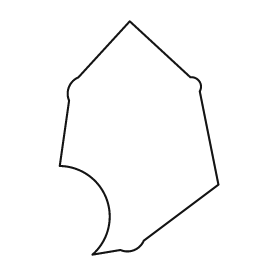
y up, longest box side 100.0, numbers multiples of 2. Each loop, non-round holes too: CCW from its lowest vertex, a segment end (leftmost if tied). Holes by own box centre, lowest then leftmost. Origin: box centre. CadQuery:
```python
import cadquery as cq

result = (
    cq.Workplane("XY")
    .moveTo(-20.0, -50.0)
    .lineTo(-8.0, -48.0)
    .threePointArc((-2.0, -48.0), (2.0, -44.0))
    .lineTo(34.0, -20.0)
    .lineTo(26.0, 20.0)
    .threePointArc((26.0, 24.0), (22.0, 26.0))
    .lineTo(-4.0, 50.0)
    .lineTo(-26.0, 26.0)
    .threePointArc((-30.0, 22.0), (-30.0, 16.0))
    .lineTo(-34.0, -12.0)
    .threePointArc((-14.0, -26.0), (-20.0, -50.0))
    .close()
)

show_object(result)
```